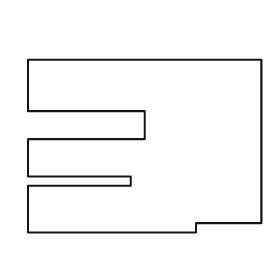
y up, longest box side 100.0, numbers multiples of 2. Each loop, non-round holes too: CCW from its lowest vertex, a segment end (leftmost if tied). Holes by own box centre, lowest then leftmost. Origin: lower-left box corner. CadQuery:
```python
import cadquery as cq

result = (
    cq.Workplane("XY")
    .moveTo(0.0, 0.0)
    .lineTo(72.0, 0.0)
    .lineTo(72.0, 4.0)
    .lineTo(100.0, 4.0)
    .lineTo(100.0, 74.0)
    .lineTo(0.0, 74.0)
    .lineTo(0.0, 52.0)
    .lineTo(50.0, 52.0)
    .lineTo(50.0, 40.0)
    .lineTo(0.0, 40.0)
    .lineTo(0.0, 24.0)
    .lineTo(44.0, 24.0)
    .lineTo(44.0, 20.0)
    .lineTo(0.0, 20.0)
    .close()
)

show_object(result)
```